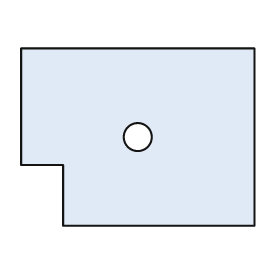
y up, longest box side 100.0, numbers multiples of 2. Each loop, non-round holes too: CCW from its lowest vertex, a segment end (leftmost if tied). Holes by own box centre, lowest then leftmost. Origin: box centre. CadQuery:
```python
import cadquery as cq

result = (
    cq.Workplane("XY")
    .moveTo(-32.0, -38.0)
    .lineTo(50.0, -38.0)
    .lineTo(50.0, 38.0)
    .lineTo(-50.0, 38.0)
    .lineTo(-50.0, -12.0)
    .lineTo(-32.0, -12.0)
    .close()
    .moveTo(0.0, 0.0)
    .circle(6.0)
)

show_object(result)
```